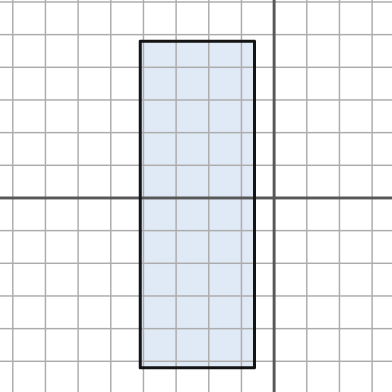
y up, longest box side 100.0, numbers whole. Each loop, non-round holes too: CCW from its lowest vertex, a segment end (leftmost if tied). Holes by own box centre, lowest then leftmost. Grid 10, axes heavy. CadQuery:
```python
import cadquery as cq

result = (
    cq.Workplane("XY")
    .moveTo(-41.0, -52.0)
    .lineTo(-6.0, -52.0)
    .lineTo(-6.0, 48.0)
    .lineTo(-41.0, 48.0)
    .close()
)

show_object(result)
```